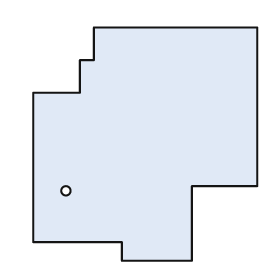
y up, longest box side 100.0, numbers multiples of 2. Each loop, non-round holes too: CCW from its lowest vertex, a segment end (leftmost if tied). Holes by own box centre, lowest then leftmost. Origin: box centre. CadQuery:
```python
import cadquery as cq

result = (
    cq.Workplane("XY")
    .moveTo(-10.0, -50.0)
    .lineTo(20.0, -50.0)
    .lineTo(20.0, -18.0)
    .lineTo(48.0, -18.0)
    .lineTo(48.0, 50.0)
    .lineTo(-22.0, 50.0)
    .lineTo(-22.0, 36.0)
    .lineTo(-28.0, 36.0)
    .lineTo(-28.0, 22.0)
    .lineTo(-48.0, 22.0)
    .lineTo(-48.0, -42.0)
    .lineTo(-10.0, -42.0)
    .close()
    .moveTo(-34.0, -20.0)
    .circle(2.0)
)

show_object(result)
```